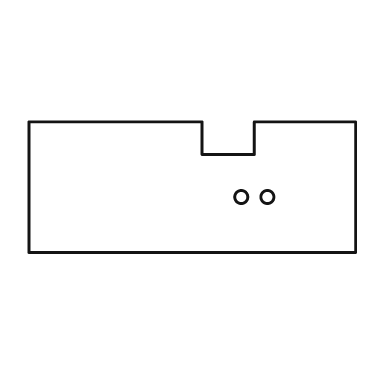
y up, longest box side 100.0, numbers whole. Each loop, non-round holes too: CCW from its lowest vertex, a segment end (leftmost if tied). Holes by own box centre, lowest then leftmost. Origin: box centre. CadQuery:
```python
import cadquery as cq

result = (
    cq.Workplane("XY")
    .moveTo(-50.0, -20.0)
    .lineTo(50.0, -20.0)
    .lineTo(50.0, 20.0)
    .lineTo(19.0, 20.0)
    .lineTo(19.0, 10.0)
    .lineTo(3.0, 10.0)
    .lineTo(3.0, 20.0)
    .lineTo(-50.0, 20.0)
    .close()
    .moveTo(15.0, -3.0)
    .circle(2.0)
    .moveTo(23.0, -3.0)
    .circle(2.0)
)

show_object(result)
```